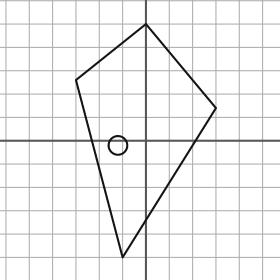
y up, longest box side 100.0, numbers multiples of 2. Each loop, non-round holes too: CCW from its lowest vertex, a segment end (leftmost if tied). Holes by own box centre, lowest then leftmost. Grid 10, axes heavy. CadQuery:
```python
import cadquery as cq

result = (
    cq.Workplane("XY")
    .moveTo(-10.0, -50.0)
    .lineTo(30.0, 14.0)
    .lineTo(0.0, 50.0)
    .lineTo(-30.0, 26.0)
    .close()
    .moveTo(-12.0, -2.0)
    .circle(4.0)
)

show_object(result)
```